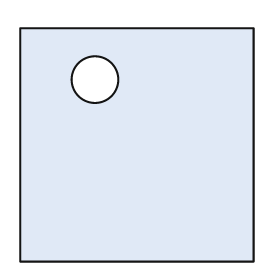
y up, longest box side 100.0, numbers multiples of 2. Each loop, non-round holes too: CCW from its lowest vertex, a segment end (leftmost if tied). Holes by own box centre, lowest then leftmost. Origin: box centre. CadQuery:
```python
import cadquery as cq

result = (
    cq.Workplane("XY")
    .moveTo(-50.0, -50.0)
    .lineTo(50.0, -50.0)
    .lineTo(50.0, 50.0)
    .lineTo(-50.0, 50.0)
    .close()
    .moveTo(-18.0, 28.0)
    .circle(10.0)
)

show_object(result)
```